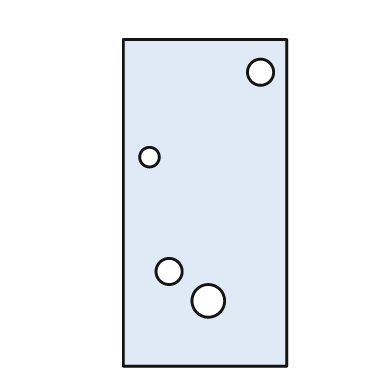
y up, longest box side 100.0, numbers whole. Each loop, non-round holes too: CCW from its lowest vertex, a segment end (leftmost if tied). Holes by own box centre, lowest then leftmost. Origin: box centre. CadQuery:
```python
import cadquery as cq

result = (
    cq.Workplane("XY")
    .moveTo(-25.0, -50.0)
    .lineTo(25.0, -50.0)
    .lineTo(25.0, 50.0)
    .lineTo(-25.0, 50.0)
    .close()
    .moveTo(1.0, -30.0)
    .circle(5.0)
    .moveTo(-11.0, -21.0)
    .circle(4.0)
    .moveTo(-17.0, 14.0)
    .circle(3.0)
    .moveTo(17.0, 40.0)
    .circle(4.0)
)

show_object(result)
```